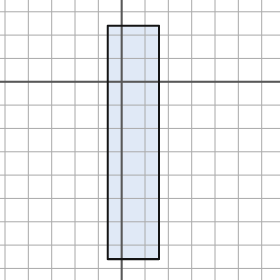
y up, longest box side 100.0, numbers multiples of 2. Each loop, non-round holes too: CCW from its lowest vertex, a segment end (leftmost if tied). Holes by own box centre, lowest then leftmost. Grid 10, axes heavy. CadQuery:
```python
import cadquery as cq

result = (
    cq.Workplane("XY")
    .moveTo(-6.0, -76.0)
    .lineTo(16.0, -76.0)
    .lineTo(16.0, 24.0)
    .lineTo(-6.0, 24.0)
    .close()
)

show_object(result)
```